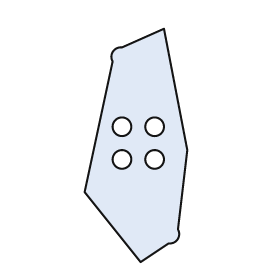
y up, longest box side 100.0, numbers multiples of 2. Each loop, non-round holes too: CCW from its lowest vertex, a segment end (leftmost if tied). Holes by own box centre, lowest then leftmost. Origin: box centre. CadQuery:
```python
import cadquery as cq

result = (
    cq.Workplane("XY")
    .moveTo(2.0, -50.0)
    .lineTo(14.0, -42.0)
    .threePointArc((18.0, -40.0), (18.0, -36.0))
    .lineTo(22.0, -2.0)
    .lineTo(12.0, 50.0)
    .lineTo(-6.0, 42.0)
    .threePointArc((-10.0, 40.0), (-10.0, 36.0))
    .lineTo(-22.0, -20.0)
    .close()
    .moveTo(-6.0, -6.0)
    .circle(4.0)
    .moveTo(8.0, -6.0)
    .circle(4.0)
    .moveTo(-6.0, 8.0)
    .circle(4.0)
    .moveTo(8.0, 8.0)
    .circle(4.0)
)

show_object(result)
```